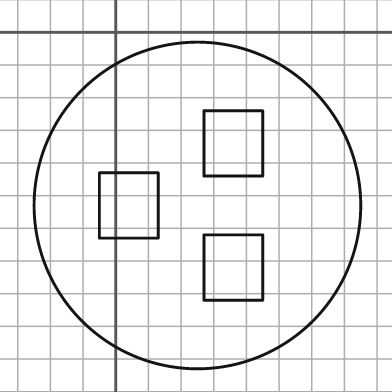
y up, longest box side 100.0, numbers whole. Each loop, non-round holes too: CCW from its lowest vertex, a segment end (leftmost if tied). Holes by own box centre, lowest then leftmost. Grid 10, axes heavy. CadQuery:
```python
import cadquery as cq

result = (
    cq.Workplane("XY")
    .moveTo(25.0, -53.0)
    .circle(50.0)
    .moveTo(27.0, -82.0)
    .lineTo(45.0, -82.0)
    .lineTo(45.0, -62.0)
    .lineTo(27.0, -62.0)
    .close()
    .moveTo(-5.0, -63.0)
    .lineTo(13.0, -63.0)
    .lineTo(13.0, -43.0)
    .lineTo(-5.0, -43.0)
    .close()
    .moveTo(27.0, -44.0)
    .lineTo(45.0, -44.0)
    .lineTo(45.0, -24.0)
    .lineTo(27.0, -24.0)
    .close()
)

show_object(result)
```